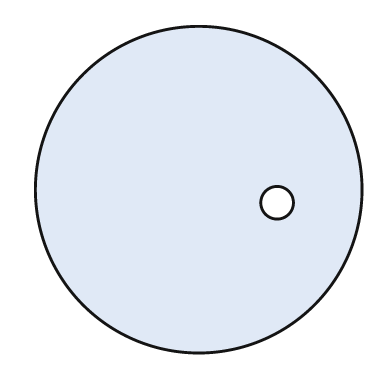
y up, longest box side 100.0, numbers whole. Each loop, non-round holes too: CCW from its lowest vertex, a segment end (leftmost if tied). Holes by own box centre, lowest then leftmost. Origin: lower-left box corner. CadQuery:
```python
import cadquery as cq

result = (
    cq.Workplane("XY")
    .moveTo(50.0, 50.0)
    .circle(50.0)
    .moveTo(74.0, 46.0)
    .circle(5.0)
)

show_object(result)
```